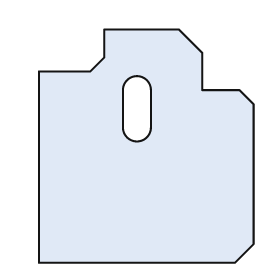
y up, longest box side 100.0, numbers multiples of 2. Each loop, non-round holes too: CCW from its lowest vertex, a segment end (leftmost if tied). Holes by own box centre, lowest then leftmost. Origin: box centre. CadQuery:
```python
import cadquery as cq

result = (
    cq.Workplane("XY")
    .moveTo(-46.0, -50.0)
    .lineTo(38.0, -50.0)
    .lineTo(46.0, -42.0)
    .lineTo(46.0, 18.0)
    .lineTo(40.0, 24.0)
    .lineTo(24.0, 24.0)
    .lineTo(24.0, 40.0)
    .lineTo(14.0, 50.0)
    .lineTo(-18.0, 50.0)
    .lineTo(-18.0, 38.0)
    .lineTo(-24.0, 32.0)
    .lineTo(-46.0, 32.0)
    .close()
    .moveTo(-10.0, 8.0)
    .threePointArc((-4.0, 2.0), (2.0, 8.0))
    .lineTo(2.0, 24.0)
    .threePointArc((-4.0, 30.0), (-10.0, 24.0))
    .close()
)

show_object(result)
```